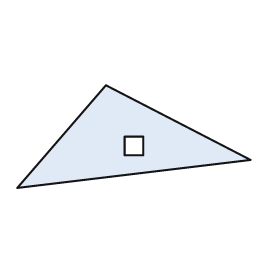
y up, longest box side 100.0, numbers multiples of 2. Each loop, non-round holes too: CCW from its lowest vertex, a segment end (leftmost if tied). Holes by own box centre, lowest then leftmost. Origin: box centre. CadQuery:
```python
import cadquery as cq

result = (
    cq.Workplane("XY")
    .moveTo(-50.0, -22.0)
    .lineTo(50.0, -10.0)
    .lineTo(-12.0, 22.0)
    .close()
    .moveTo(-4.0, -8.0)
    .lineTo(4.0, -8.0)
    .lineTo(4.0, 0.0)
    .lineTo(-4.0, 0.0)
    .close()
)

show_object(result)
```